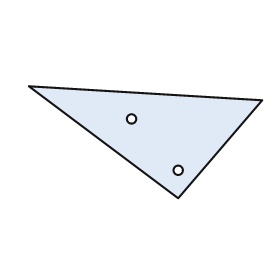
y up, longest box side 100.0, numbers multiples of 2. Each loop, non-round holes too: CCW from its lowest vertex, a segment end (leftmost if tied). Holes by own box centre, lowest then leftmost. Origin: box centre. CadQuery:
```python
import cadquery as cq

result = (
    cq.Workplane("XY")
    .moveTo(14.0, -24.0)
    .lineTo(50.0, 18.0)
    .lineTo(-50.0, 24.0)
    .close()
    .moveTo(14.0, -12.0)
    .circle(2.0)
    .moveTo(-6.0, 10.0)
    .circle(2.0)
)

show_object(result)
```